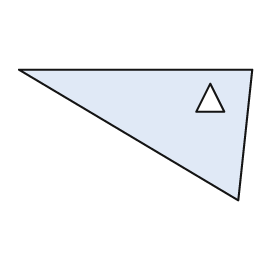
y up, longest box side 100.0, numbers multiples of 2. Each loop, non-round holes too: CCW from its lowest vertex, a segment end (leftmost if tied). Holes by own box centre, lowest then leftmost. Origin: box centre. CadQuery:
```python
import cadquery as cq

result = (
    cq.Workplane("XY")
    .moveTo(44.0, -28.0)
    .lineTo(50.0, 28.0)
    .lineTo(-50.0, 28.0)
    .close()
    .moveTo(26.0, 10.0)
    .lineTo(38.0, 10.0)
    .lineTo(32.0, 22.0)
    .close()
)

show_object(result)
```